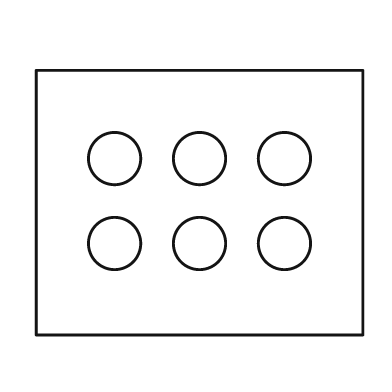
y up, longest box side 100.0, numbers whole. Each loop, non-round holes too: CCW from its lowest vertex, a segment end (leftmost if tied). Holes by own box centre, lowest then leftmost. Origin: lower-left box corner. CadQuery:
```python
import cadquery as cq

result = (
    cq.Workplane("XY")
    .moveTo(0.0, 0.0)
    .lineTo(100.0, 0.0)
    .lineTo(100.0, 81.0)
    .lineTo(0.0, 81.0)
    .close()
    .moveTo(24.0, 28.0)
    .circle(8.0)
    .moveTo(50.0, 28.0)
    .circle(8.0)
    .moveTo(76.0, 28.0)
    .circle(8.0)
    .moveTo(24.0, 54.0)
    .circle(8.0)
    .moveTo(50.0, 54.0)
    .circle(8.0)
    .moveTo(76.0, 54.0)
    .circle(8.0)
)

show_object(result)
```